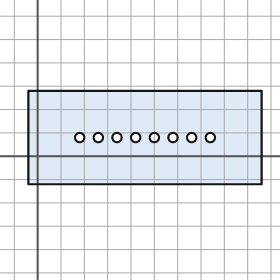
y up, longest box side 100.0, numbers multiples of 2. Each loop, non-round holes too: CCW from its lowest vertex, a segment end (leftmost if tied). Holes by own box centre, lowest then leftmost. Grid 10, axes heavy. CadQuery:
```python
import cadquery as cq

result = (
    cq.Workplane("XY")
    .moveTo(-4.0, -12.0)
    .lineTo(96.0, -12.0)
    .lineTo(96.0, 28.0)
    .lineTo(-4.0, 28.0)
    .close()
    .moveTo(18.0, 8.0)
    .circle(2.0)
    .moveTo(26.0, 8.0)
    .circle(2.0)
    .moveTo(34.0, 8.0)
    .circle(2.0)
    .moveTo(42.0, 8.0)
    .circle(2.0)
    .moveTo(50.0, 8.0)
    .circle(2.0)
    .moveTo(58.0, 8.0)
    .circle(2.0)
    .moveTo(66.0, 8.0)
    .circle(2.0)
    .moveTo(74.0, 8.0)
    .circle(2.0)
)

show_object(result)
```